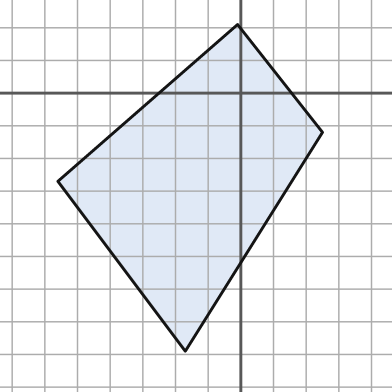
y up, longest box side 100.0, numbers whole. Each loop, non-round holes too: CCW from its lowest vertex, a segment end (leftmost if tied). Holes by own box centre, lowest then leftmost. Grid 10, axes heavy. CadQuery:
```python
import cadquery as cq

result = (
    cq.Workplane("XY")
    .moveTo(-17.0, -79.0)
    .lineTo(25.0, -12.0)
    .lineTo(-1.0, 21.0)
    .lineTo(-56.0, -27.0)
    .close()
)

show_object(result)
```